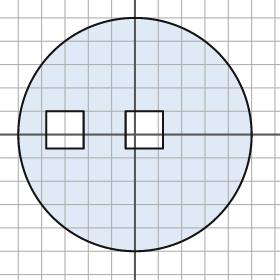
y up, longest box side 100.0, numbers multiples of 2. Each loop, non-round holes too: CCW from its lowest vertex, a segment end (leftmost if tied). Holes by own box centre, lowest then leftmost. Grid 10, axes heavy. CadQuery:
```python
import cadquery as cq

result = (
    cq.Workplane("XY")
    .moveTo(0.0, 0.0)
    .circle(50.0)
    .moveTo(-38.0, -6.0)
    .lineTo(-22.0, -6.0)
    .lineTo(-22.0, 10.0)
    .lineTo(-38.0, 10.0)
    .close()
    .moveTo(-4.0, -6.0)
    .lineTo(12.0, -6.0)
    .lineTo(12.0, 10.0)
    .lineTo(-4.0, 10.0)
    .close()
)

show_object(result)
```